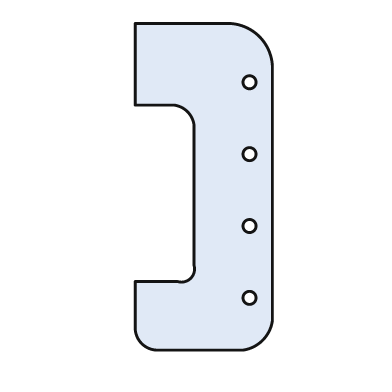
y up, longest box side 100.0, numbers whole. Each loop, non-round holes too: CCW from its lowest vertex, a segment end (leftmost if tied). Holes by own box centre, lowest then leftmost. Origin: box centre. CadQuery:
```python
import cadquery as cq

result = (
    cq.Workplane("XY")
    .moveTo(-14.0, -50.0)
    .lineTo(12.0, -50.0)
    .threePointArc((18.0, -47.0), (21.0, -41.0))
    .lineTo(21.0, 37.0)
    .threePointArc((17.0, 46.0), (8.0, 50.0))
    .lineTo(-21.0, 50.0)
    .lineTo(-21.0, 25.0)
    .lineTo(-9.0, 25.0)
    .threePointArc((-5.0, 23.0), (-3.0, 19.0))
    .lineTo(-3.0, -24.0)
    .threePointArc((-4.0, -28.0), (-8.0, -29.0))
    .lineTo(-21.0, -29.0)
    .lineTo(-21.0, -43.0)
    .threePointArc((-19.0, -48.0), (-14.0, -50.0))
    .close()
    .moveTo(14.0, -34.0)
    .circle(2.0)
    .moveTo(14.0, -12.0)
    .circle(2.0)
    .moveTo(14.0, 10.0)
    .circle(2.0)
    .moveTo(14.0, 32.0)
    .circle(2.0)
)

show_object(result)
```